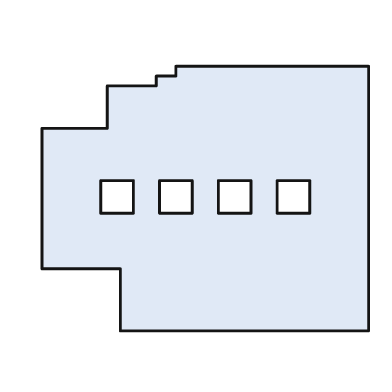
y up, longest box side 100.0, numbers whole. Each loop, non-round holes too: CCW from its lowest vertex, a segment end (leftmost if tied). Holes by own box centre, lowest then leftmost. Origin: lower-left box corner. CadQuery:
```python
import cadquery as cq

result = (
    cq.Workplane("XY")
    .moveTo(24.0, 0.0)
    .lineTo(100.0, 0.0)
    .lineTo(100.0, 81.0)
    .lineTo(41.0, 81.0)
    .lineTo(41.0, 78.0)
    .lineTo(35.0, 78.0)
    .lineTo(35.0, 75.0)
    .lineTo(20.0, 75.0)
    .lineTo(20.0, 62.0)
    .lineTo(0.0, 62.0)
    .lineTo(0.0, 19.0)
    .lineTo(24.0, 19.0)
    .close()
    .moveTo(18.0, 36.0)
    .lineTo(28.0, 36.0)
    .lineTo(28.0, 46.0)
    .lineTo(18.0, 46.0)
    .close()
    .moveTo(36.0, 36.0)
    .lineTo(46.0, 36.0)
    .lineTo(46.0, 46.0)
    .lineTo(36.0, 46.0)
    .close()
    .moveTo(54.0, 36.0)
    .lineTo(64.0, 36.0)
    .lineTo(64.0, 46.0)
    .lineTo(54.0, 46.0)
    .close()
    .moveTo(72.0, 36.0)
    .lineTo(82.0, 36.0)
    .lineTo(82.0, 46.0)
    .lineTo(72.0, 46.0)
    .close()
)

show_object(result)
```